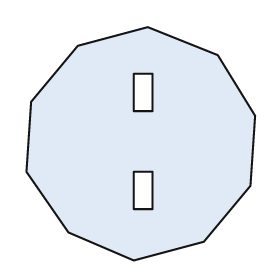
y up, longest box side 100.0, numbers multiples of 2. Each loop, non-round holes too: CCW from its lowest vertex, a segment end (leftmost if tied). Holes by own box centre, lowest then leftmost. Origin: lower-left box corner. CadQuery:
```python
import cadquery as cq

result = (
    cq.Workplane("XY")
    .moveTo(46.0, 0.0)
    .lineTo(76.0, 8.0)
    .lineTo(96.0, 32.0)
    .lineTo(98.0, 62.0)
    .lineTo(82.0, 88.0)
    .lineTo(52.0, 100.0)
    .lineTo(22.0, 92.0)
    .lineTo(2.0, 68.0)
    .lineTo(0.0, 38.0)
    .lineTo(18.0, 12.0)
    .close()
    .moveTo(46.0, 22.0)
    .lineTo(54.0, 22.0)
    .lineTo(54.0, 38.0)
    .lineTo(46.0, 38.0)
    .close()
    .moveTo(46.0, 64.0)
    .lineTo(54.0, 64.0)
    .lineTo(54.0, 80.0)
    .lineTo(46.0, 80.0)
    .close()
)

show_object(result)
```